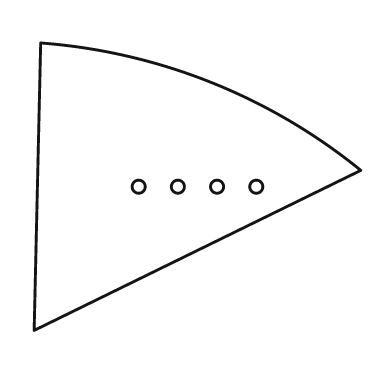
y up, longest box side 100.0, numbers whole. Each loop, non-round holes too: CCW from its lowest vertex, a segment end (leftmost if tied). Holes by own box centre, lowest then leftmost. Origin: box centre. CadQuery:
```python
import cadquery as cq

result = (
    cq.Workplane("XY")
    .moveTo(-50.0, -44.0)
    .lineTo(50.0, 5.0)
    .threePointArc((4.0, 32.0), (-48.0, 44.0))
    .close()
    .moveTo(-18.0, 0.0)
    .circle(2.0)
    .moveTo(-6.0, 0.0)
    .circle(2.0)
    .moveTo(6.0, 0.0)
    .circle(2.0)
    .moveTo(18.0, 0.0)
    .circle(2.0)
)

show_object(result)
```